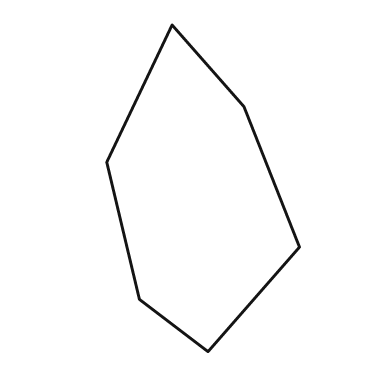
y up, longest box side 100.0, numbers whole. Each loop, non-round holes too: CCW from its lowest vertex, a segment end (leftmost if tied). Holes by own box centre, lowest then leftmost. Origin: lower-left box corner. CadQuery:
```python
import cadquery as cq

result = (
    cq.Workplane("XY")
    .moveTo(31.0, 0.0)
    .lineTo(59.0, 32.0)
    .lineTo(42.0, 75.0)
    .lineTo(20.0, 100.0)
    .lineTo(0.0, 58.0)
    .lineTo(10.0, 16.0)
    .close()
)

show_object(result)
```